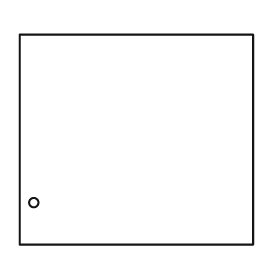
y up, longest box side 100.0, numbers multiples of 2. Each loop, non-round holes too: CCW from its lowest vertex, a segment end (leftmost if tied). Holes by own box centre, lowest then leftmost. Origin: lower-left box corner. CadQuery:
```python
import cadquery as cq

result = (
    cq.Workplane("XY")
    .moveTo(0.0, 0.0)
    .lineTo(100.0, 0.0)
    .lineTo(100.0, 90.0)
    .lineTo(0.0, 90.0)
    .close()
    .moveTo(6.0, 18.0)
    .circle(2.0)
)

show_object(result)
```